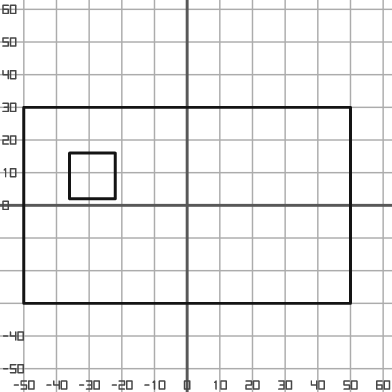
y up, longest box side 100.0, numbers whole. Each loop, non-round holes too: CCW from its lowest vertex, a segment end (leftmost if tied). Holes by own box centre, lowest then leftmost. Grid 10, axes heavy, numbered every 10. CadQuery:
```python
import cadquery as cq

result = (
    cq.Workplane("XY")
    .moveTo(-50.0, -30.0)
    .lineTo(50.0, -30.0)
    .lineTo(50.0, 30.0)
    .lineTo(-50.0, 30.0)
    .close()
    .moveTo(-36.0, 2.0)
    .lineTo(-22.0, 2.0)
    .lineTo(-22.0, 16.0)
    .lineTo(-36.0, 16.0)
    .close()
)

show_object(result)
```